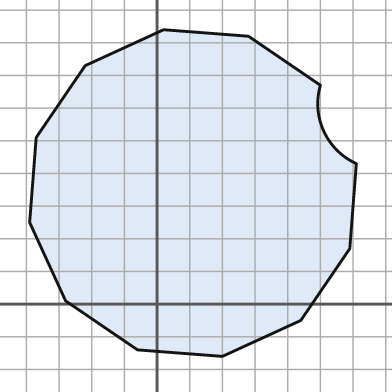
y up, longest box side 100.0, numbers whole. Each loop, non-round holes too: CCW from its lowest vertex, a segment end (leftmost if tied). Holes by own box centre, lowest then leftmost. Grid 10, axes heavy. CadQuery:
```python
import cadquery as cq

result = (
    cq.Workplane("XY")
    .moveTo(20.0, -16.0)
    .lineTo(44.0, -5.0)
    .lineTo(59.0, 17.0)
    .lineTo(61.0, 43.0)
    .threePointArc((51.0, 53.0), (50.0, 67.0))
    .lineTo(28.0, 82.0)
    .lineTo(2.0, 84.0)
    .lineTo(-22.0, 73.0)
    .lineTo(-37.0, 51.0)
    .lineTo(-39.0, 25.0)
    .lineTo(-28.0, 1.0)
    .lineTo(-6.0, -14.0)
    .close()
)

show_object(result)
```